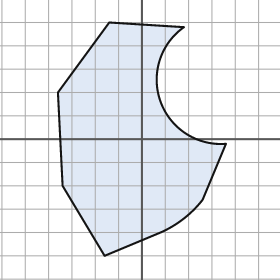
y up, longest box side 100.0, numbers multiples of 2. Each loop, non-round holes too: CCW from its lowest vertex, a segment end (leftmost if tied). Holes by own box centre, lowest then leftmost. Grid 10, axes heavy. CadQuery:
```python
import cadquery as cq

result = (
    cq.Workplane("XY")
    .moveTo(-16.0, -50.0)
    .lineTo(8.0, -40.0)
    .threePointArc((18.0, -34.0), (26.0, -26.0))
    .lineTo(36.0, -2.0)
    .threePointArc((8.0, 16.0), (18.0, 48.0))
    .lineTo(-14.0, 50.0)
    .lineTo(-36.0, 20.0)
    .lineTo(-34.0, -20.0)
    .close()
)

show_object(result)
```